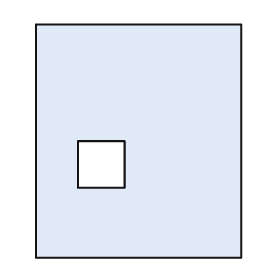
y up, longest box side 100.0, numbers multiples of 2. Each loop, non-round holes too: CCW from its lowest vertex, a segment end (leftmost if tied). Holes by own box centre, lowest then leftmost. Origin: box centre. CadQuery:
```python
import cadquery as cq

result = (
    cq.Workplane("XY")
    .moveTo(-44.0, -50.0)
    .lineTo(44.0, -50.0)
    .lineTo(44.0, 50.0)
    .lineTo(-44.0, 50.0)
    .close()
    .moveTo(-26.0, -20.0)
    .lineTo(-6.0, -20.0)
    .lineTo(-6.0, 0.0)
    .lineTo(-26.0, 0.0)
    .close()
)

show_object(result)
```